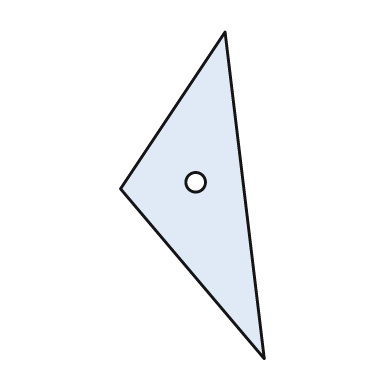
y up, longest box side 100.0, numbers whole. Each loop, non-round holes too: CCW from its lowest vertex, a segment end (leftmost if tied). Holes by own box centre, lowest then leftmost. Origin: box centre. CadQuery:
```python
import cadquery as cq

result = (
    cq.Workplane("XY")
    .moveTo(22.0, -50.0)
    .lineTo(10.0, 50.0)
    .lineTo(-22.0, 2.0)
    .close()
    .moveTo(1.0, 4.0)
    .circle(3.0)
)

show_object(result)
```